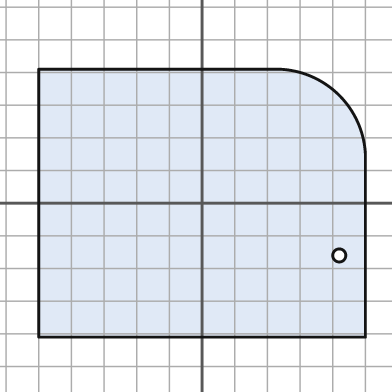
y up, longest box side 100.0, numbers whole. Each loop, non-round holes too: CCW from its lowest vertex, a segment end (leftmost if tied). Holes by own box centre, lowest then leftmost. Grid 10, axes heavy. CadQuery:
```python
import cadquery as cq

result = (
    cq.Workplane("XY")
    .moveTo(-50.0, -41.0)
    .lineTo(50.0, -41.0)
    .lineTo(50.0, 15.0)
    .threePointArc((42.0, 33.0), (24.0, 41.0))
    .lineTo(-50.0, 41.0)
    .close()
    .moveTo(42.0, -16.0)
    .circle(2.0)
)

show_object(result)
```